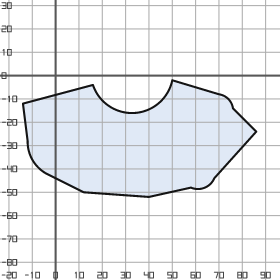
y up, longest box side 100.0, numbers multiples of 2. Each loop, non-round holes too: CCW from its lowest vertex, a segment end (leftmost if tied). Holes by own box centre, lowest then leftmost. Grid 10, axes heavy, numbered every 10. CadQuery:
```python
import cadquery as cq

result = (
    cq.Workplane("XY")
    .moveTo(40.0, -52.0)
    .lineTo(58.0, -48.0)
    .threePointArc((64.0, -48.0), (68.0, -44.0))
    .lineTo(86.0, -24.0)
    .lineTo(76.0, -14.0)
    .threePointArc((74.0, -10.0), (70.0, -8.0))
    .lineTo(50.0, -2.0)
    .threePointArc((34.0, -16.0), (16.0, -4.0))
    .lineTo(-14.0, -12.0)
    .lineTo(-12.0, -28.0)
    .threePointArc((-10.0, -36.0), (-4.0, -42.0))
    .lineTo(12.0, -50.0)
    .close()
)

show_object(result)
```